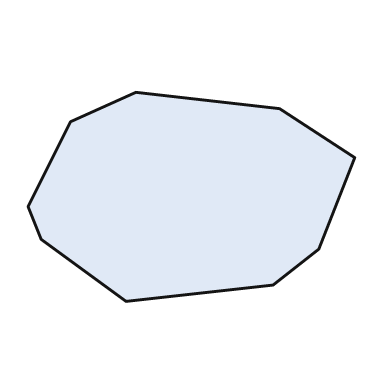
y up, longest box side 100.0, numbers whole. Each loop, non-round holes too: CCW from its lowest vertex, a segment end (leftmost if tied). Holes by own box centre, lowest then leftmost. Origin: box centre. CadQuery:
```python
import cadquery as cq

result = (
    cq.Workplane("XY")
    .moveTo(-20.0, -32.0)
    .lineTo(25.0, -27.0)
    .lineTo(39.0, -16.0)
    .lineTo(50.0, 12.0)
    .lineTo(27.0, 27.0)
    .lineTo(-17.0, 32.0)
    .lineTo(-37.0, 23.0)
    .lineTo(-50.0, -3.0)
    .lineTo(-46.0, -13.0)
    .close()
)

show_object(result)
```